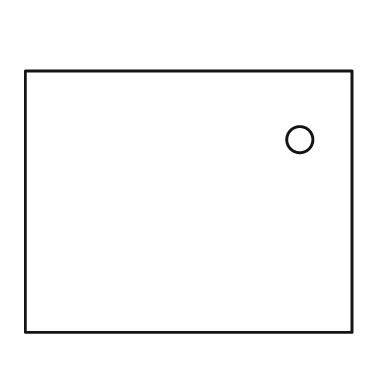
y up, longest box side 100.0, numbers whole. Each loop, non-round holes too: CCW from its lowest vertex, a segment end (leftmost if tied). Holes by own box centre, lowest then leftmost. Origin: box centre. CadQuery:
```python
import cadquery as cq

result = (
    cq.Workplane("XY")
    .moveTo(-50.0, -40.0)
    .lineTo(50.0, -40.0)
    .lineTo(50.0, 40.0)
    .lineTo(-50.0, 40.0)
    .close()
    .moveTo(34.0, 19.0)
    .circle(4.0)
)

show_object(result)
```